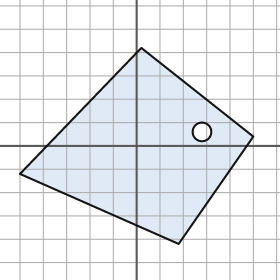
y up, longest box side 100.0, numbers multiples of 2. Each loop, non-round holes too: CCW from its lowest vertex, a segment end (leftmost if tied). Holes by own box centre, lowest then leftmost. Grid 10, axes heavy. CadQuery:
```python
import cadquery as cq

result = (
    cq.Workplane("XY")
    .moveTo(18.0, -42.0)
    .lineTo(50.0, 4.0)
    .lineTo(2.0, 42.0)
    .lineTo(-50.0, -12.0)
    .close()
    .moveTo(28.0, 6.0)
    .circle(4.0)
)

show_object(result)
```